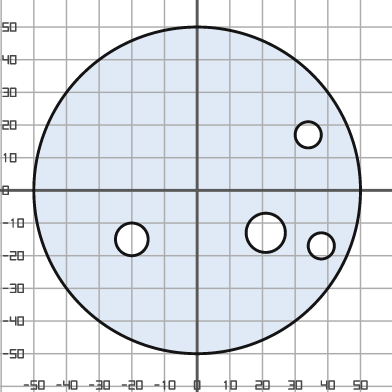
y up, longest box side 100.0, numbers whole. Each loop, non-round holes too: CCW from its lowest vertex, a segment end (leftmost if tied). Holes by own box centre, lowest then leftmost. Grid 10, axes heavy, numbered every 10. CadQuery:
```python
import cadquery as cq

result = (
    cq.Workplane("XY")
    .moveTo(0.0, 0.0)
    .circle(50.0)
    .moveTo(38.0, -17.0)
    .circle(4.0)
    .moveTo(-20.0, -15.0)
    .circle(5.0)
    .moveTo(21.0, -13.0)
    .circle(6.0)
    .moveTo(34.0, 17.0)
    .circle(4.0)
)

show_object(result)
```